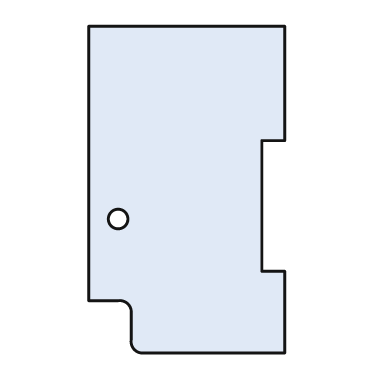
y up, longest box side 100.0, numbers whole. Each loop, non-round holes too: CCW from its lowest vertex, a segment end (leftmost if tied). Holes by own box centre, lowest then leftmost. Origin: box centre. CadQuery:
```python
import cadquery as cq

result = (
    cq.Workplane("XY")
    .moveTo(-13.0, -50.0)
    .lineTo(30.0, -50.0)
    .lineTo(30.0, -25.0)
    .lineTo(23.0, -25.0)
    .lineTo(23.0, 15.0)
    .lineTo(30.0, 15.0)
    .lineTo(30.0, 50.0)
    .lineTo(-30.0, 50.0)
    .lineTo(-30.0, -34.0)
    .lineTo(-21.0, -34.0)
    .threePointArc((-18.0, -35.0), (-17.0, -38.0))
    .lineTo(-17.0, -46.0)
    .threePointArc((-16.0, -49.0), (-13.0, -50.0))
    .close()
    .moveTo(-21.0, -9.0)
    .circle(3.0)
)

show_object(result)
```